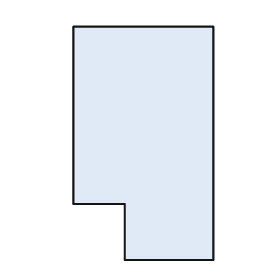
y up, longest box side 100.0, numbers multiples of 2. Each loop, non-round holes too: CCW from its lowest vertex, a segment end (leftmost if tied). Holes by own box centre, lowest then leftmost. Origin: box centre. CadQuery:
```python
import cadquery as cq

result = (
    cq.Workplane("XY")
    .moveTo(-8.0, -50.0)
    .lineTo(30.0, -50.0)
    .lineTo(30.0, 50.0)
    .lineTo(-30.0, 50.0)
    .lineTo(-30.0, -26.0)
    .lineTo(-8.0, -26.0)
    .close()
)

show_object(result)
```